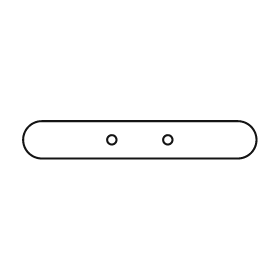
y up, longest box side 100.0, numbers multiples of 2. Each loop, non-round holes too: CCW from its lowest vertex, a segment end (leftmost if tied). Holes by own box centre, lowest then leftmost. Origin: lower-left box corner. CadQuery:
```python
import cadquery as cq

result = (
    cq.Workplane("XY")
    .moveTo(8.0, 0.0)
    .lineTo(92.0, 0.0)
    .threePointArc((100.0, 8.0), (92.0, 16.0))
    .lineTo(8.0, 16.0)
    .threePointArc((0.0, 8.0), (8.0, 0.0))
    .close()
    .moveTo(38.0, 8.0)
    .circle(2.0)
    .moveTo(62.0, 8.0)
    .circle(2.0)
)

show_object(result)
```